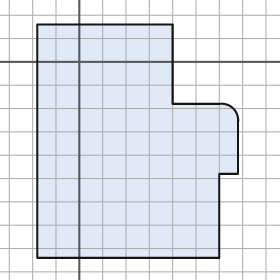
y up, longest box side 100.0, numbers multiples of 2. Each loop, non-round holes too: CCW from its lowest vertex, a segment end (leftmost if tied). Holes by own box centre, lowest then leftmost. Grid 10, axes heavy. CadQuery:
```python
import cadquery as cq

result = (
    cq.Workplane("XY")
    .moveTo(-18.0, -84.0)
    .lineTo(60.0, -84.0)
    .lineTo(60.0, -48.0)
    .lineTo(68.0, -48.0)
    .lineTo(68.0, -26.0)
    .threePointArc((66.0, -20.0), (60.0, -18.0))
    .lineTo(40.0, -18.0)
    .lineTo(40.0, 16.0)
    .lineTo(-18.0, 16.0)
    .close()
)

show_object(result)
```